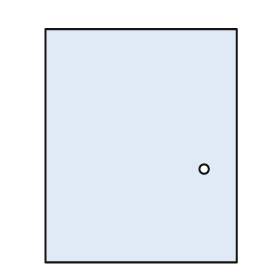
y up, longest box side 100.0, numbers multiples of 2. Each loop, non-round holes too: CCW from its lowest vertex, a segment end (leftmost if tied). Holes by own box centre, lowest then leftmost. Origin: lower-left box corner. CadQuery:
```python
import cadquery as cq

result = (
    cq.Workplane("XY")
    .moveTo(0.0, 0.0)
    .lineTo(82.0, 0.0)
    .lineTo(82.0, 100.0)
    .lineTo(0.0, 100.0)
    .close()
    .moveTo(68.0, 40.0)
    .circle(2.0)
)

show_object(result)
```